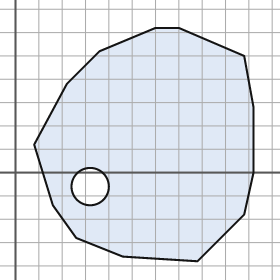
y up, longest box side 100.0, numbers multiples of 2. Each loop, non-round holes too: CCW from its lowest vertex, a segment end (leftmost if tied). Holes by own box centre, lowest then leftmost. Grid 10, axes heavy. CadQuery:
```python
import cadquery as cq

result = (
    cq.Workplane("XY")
    .moveTo(78.0, -38.0)
    .lineTo(98.0, -18.0)
    .lineTo(102.0, 0.0)
    .lineTo(102.0, 28.0)
    .lineTo(98.0, 50.0)
    .lineTo(70.0, 62.0)
    .lineTo(60.0, 62.0)
    .lineTo(36.0, 52.0)
    .lineTo(22.0, 38.0)
    .lineTo(8.0, 12.0)
    .lineTo(16.0, -14.0)
    .lineTo(26.0, -28.0)
    .lineTo(46.0, -36.0)
    .close()
    .moveTo(32.0, -6.0)
    .circle(8.0)
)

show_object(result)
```